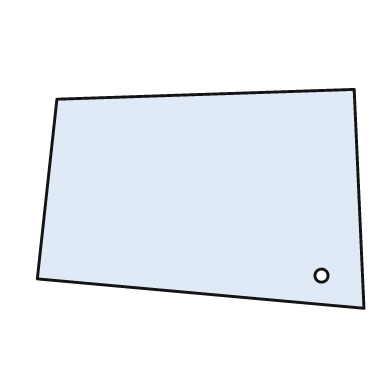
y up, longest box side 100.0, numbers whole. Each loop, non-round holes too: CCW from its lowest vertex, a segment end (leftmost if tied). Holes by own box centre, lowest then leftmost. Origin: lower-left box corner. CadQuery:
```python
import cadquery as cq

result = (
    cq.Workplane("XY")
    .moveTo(100.0, 0.0)
    .lineTo(97.0, 67.0)
    .lineTo(6.0, 64.0)
    .lineTo(0.0, 9.0)
    .close()
    .moveTo(87.0, 10.0)
    .circle(2.0)
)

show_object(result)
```